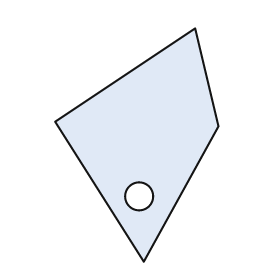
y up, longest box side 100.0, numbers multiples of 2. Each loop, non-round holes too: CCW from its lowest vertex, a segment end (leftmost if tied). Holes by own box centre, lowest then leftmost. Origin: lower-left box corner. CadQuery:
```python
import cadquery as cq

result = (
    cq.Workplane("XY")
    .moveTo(38.0, 0.0)
    .lineTo(70.0, 58.0)
    .lineTo(60.0, 100.0)
    .lineTo(0.0, 60.0)
    .close()
    .moveTo(36.0, 28.0)
    .circle(6.0)
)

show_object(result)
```